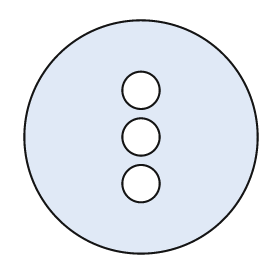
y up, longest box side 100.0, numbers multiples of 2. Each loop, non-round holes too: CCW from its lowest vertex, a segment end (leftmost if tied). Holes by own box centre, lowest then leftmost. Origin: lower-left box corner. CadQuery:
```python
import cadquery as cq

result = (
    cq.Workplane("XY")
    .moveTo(50.0, 50.0)
    .circle(50.0)
    .moveTo(50.0, 30.0)
    .circle(8.0)
    .moveTo(50.0, 50.0)
    .circle(8.0)
    .moveTo(50.0, 70.0)
    .circle(8.0)
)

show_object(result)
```